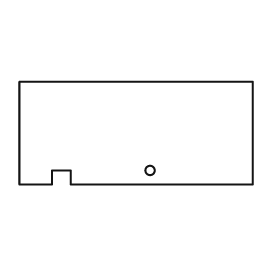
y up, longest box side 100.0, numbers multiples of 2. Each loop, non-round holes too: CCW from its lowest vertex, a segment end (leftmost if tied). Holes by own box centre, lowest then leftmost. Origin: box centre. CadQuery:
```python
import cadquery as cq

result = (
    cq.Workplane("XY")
    .moveTo(-50.0, -22.0)
    .lineTo(-36.0, -22.0)
    .lineTo(-36.0, -16.0)
    .lineTo(-28.0, -16.0)
    .lineTo(-28.0, -22.0)
    .lineTo(50.0, -22.0)
    .lineTo(50.0, 22.0)
    .lineTo(-50.0, 22.0)
    .close()
    .moveTo(6.0, -16.0)
    .circle(2.0)
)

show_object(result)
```